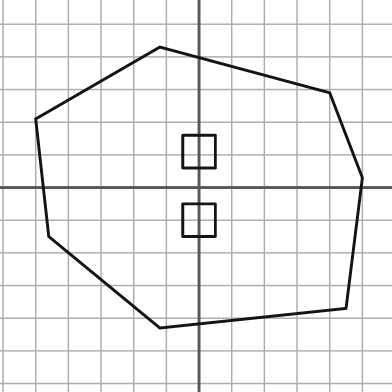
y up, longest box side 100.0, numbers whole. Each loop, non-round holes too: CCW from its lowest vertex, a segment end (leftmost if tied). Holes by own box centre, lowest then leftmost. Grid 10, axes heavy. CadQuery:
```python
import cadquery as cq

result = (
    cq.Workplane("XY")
    .moveTo(-12.0, -43.0)
    .lineTo(45.0, -37.0)
    .lineTo(50.0, 3.0)
    .lineTo(40.0, 29.0)
    .lineTo(-12.0, 43.0)
    .lineTo(-50.0, 21.0)
    .lineTo(-46.0, -15.0)
    .close()
    .moveTo(-5.0, -15.0)
    .lineTo(5.0, -15.0)
    .lineTo(5.0, -5.0)
    .lineTo(-5.0, -5.0)
    .close()
    .moveTo(-5.0, 6.0)
    .lineTo(5.0, 6.0)
    .lineTo(5.0, 16.0)
    .lineTo(-5.0, 16.0)
    .close()
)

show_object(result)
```